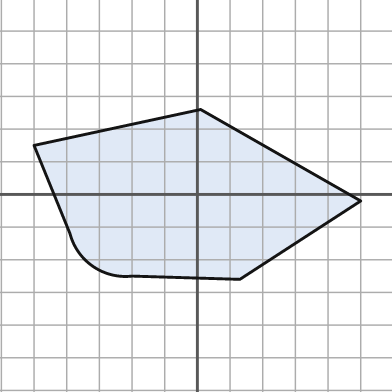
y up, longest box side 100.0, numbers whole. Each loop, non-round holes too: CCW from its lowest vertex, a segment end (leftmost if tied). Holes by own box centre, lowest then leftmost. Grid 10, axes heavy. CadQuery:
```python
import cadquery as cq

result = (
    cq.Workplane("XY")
    .moveTo(13.0, -26.0)
    .lineTo(50.0, -2.0)
    .lineTo(1.0, 26.0)
    .lineTo(-50.0, 15.0)
    .lineTo(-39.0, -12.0)
    .threePointArc((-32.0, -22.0), (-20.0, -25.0))
    .close()
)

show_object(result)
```